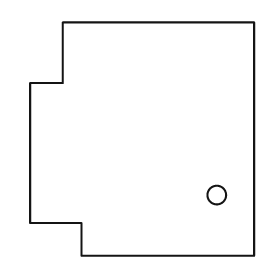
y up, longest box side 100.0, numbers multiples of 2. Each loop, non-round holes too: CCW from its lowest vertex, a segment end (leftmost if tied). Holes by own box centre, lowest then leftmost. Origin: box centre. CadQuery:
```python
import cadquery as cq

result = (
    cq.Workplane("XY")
    .moveTo(-26.0, -50.0)
    .lineTo(48.0, -50.0)
    .lineTo(48.0, 50.0)
    .lineTo(-34.0, 50.0)
    .lineTo(-34.0, 24.0)
    .lineTo(-48.0, 24.0)
    .lineTo(-48.0, -36.0)
    .lineTo(-26.0, -36.0)
    .close()
    .moveTo(32.0, -24.0)
    .circle(4.0)
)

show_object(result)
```